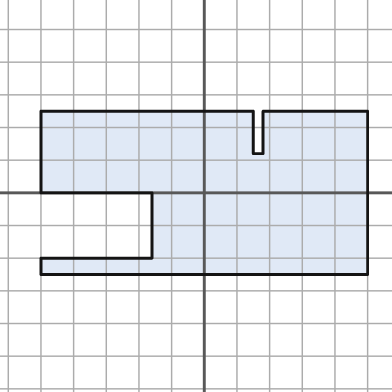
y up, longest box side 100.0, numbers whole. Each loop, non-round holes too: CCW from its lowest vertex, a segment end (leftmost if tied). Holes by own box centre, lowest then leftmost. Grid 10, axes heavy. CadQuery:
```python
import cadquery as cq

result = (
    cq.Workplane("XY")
    .moveTo(-50.0, -25.0)
    .lineTo(50.0, -25.0)
    .lineTo(50.0, 25.0)
    .lineTo(18.0, 25.0)
    .lineTo(18.0, 12.0)
    .lineTo(15.0, 12.0)
    .lineTo(15.0, 25.0)
    .lineTo(-50.0, 25.0)
    .lineTo(-50.0, 0.0)
    .lineTo(-16.0, 0.0)
    .lineTo(-16.0, -20.0)
    .lineTo(-50.0, -20.0)
    .close()
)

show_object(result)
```